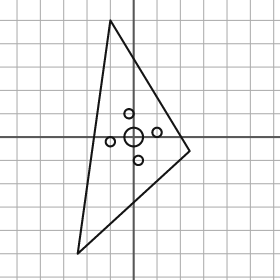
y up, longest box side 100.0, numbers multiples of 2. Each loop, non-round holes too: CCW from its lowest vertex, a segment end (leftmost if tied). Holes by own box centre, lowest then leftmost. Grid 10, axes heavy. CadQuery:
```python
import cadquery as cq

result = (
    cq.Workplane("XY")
    .moveTo(-24.0, -50.0)
    .lineTo(24.0, -6.0)
    .lineTo(-10.0, 50.0)
    .close()
    .moveTo(2.0, -10.0)
    .circle(2.0)
    .moveTo(-10.0, -2.0)
    .circle(2.0)
    .moveTo(0.0, 0.0)
    .circle(4.0)
    .moveTo(10.0, 2.0)
    .circle(2.0)
    .moveTo(-2.0, 10.0)
    .circle(2.0)
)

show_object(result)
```